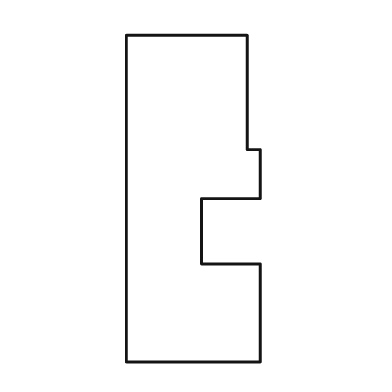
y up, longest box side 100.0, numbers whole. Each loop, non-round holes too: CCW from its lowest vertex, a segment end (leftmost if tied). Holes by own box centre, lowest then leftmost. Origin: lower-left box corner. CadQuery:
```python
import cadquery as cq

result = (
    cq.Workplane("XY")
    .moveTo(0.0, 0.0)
    .lineTo(41.0, 0.0)
    .lineTo(41.0, 30.0)
    .lineTo(23.0, 30.0)
    .lineTo(23.0, 50.0)
    .lineTo(41.0, 50.0)
    .lineTo(41.0, 65.0)
    .lineTo(37.0, 65.0)
    .lineTo(37.0, 100.0)
    .lineTo(0.0, 100.0)
    .close()
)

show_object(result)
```